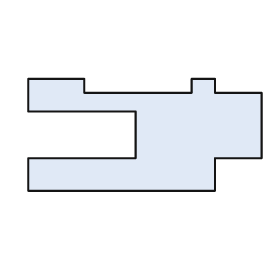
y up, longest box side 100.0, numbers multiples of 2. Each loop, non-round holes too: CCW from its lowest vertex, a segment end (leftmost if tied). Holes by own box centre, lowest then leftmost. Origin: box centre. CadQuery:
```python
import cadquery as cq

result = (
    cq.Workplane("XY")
    .moveTo(-50.0, -24.0)
    .lineTo(30.0, -24.0)
    .lineTo(30.0, -10.0)
    .lineTo(50.0, -10.0)
    .lineTo(50.0, 18.0)
    .lineTo(30.0, 18.0)
    .lineTo(30.0, 24.0)
    .lineTo(20.0, 24.0)
    .lineTo(20.0, 18.0)
    .lineTo(-26.0, 18.0)
    .lineTo(-26.0, 24.0)
    .lineTo(-50.0, 24.0)
    .lineTo(-50.0, 10.0)
    .lineTo(-4.0, 10.0)
    .lineTo(-4.0, -10.0)
    .lineTo(-50.0, -10.0)
    .close()
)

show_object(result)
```